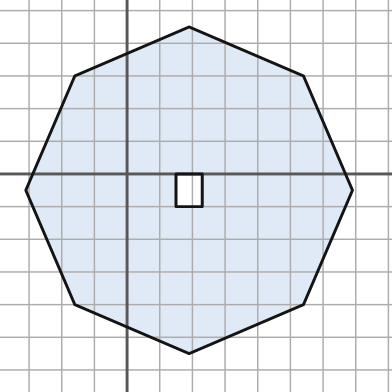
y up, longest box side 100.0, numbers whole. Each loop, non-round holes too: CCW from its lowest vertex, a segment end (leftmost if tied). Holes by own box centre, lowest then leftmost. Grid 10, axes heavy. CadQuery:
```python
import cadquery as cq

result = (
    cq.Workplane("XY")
    .moveTo(19.0, -55.0)
    .lineTo(54.0, -40.0)
    .lineTo(69.0, -5.0)
    .lineTo(54.0, 30.0)
    .lineTo(19.0, 45.0)
    .lineTo(-16.0, 30.0)
    .lineTo(-31.0, -5.0)
    .lineTo(-16.0, -40.0)
    .close()
    .moveTo(15.0, -10.0)
    .lineTo(23.0, -10.0)
    .lineTo(23.0, 0.0)
    .lineTo(15.0, 0.0)
    .close()
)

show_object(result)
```